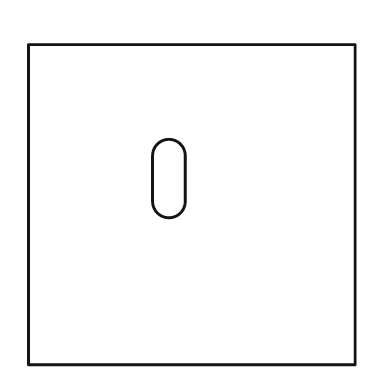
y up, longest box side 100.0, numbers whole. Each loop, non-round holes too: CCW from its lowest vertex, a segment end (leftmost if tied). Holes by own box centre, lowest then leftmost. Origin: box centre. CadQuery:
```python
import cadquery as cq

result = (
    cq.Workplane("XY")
    .moveTo(-50.0, -49.0)
    .lineTo(50.0, -49.0)
    .lineTo(50.0, 49.0)
    .lineTo(-50.0, 49.0)
    .close()
    .moveTo(-12.0, 1.0)
    .threePointArc((-7.0, -4.0), (-2.0, 1.0))
    .lineTo(-2.0, 15.0)
    .threePointArc((-7.0, 20.0), (-12.0, 15.0))
    .close()
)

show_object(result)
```